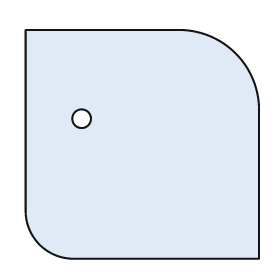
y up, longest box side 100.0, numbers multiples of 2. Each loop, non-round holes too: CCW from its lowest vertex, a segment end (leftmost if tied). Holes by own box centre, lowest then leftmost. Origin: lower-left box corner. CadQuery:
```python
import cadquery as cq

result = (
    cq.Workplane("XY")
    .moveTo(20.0, 0.0)
    .lineTo(100.0, 0.0)
    .lineTo(100.0, 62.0)
    .threePointArc((90.0, 88.0), (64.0, 98.0))
    .lineTo(0.0, 98.0)
    .lineTo(0.0, 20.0)
    .threePointArc((6.0, 6.0), (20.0, 0.0))
    .close()
    .moveTo(24.0, 60.0)
    .circle(4.0)
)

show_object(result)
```